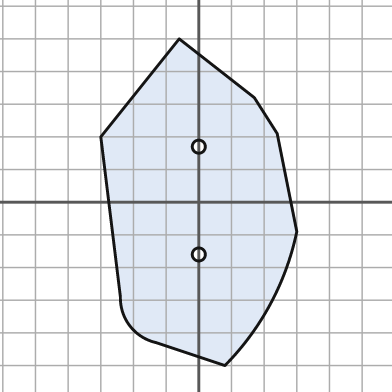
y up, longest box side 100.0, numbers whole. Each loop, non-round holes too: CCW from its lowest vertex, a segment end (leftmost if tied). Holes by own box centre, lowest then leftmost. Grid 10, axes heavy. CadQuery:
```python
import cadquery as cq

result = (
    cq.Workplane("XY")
    .moveTo(8.0, -50.0)
    .threePointArc((22.0, -31.0), (30.0, -9.0))
    .lineTo(24.0, 21.0)
    .lineTo(17.0, 32.0)
    .lineTo(-6.0, 50.0)
    .lineTo(-30.0, 20.0)
    .lineTo(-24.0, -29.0)
    .threePointArc((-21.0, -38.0), (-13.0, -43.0))
    .close()
    .moveTo(0.0, -16.0)
    .circle(2.0)
    .moveTo(0.0, 17.0)
    .circle(2.0)
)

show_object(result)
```